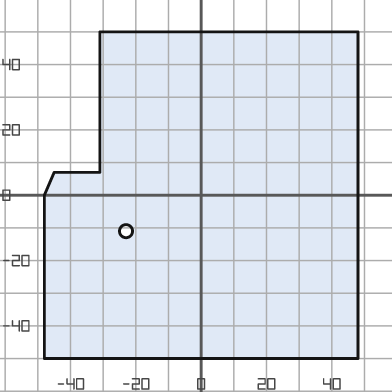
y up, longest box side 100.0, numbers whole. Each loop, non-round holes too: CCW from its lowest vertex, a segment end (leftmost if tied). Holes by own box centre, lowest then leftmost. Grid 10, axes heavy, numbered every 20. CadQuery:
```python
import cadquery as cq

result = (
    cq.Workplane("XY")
    .moveTo(-48.0, -50.0)
    .lineTo(48.0, -50.0)
    .lineTo(48.0, 50.0)
    .lineTo(-31.0, 50.0)
    .lineTo(-31.0, 7.0)
    .lineTo(-45.0, 7.0)
    .lineTo(-48.0, 0.0)
    .close()
    .moveTo(-23.0, -11.0)
    .circle(2.0)
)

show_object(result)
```